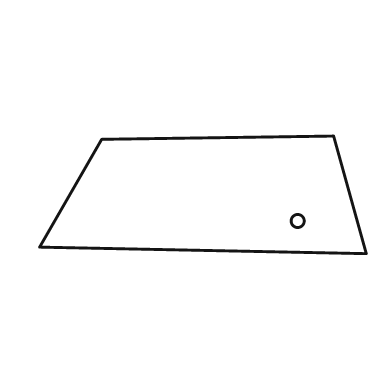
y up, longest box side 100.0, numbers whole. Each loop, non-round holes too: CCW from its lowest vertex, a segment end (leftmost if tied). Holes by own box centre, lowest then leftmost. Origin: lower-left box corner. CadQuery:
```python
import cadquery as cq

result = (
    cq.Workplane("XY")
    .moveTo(100.0, 0.0)
    .lineTo(90.0, 36.0)
    .lineTo(19.0, 35.0)
    .lineTo(0.0, 2.0)
    .close()
    .moveTo(79.0, 10.0)
    .circle(2.0)
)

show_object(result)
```